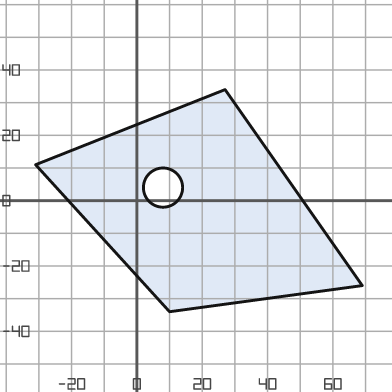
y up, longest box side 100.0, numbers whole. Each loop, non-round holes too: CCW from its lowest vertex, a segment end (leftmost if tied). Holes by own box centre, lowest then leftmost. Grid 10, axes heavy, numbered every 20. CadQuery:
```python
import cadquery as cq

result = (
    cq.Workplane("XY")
    .moveTo(10.0, -34.0)
    .lineTo(69.0, -26.0)
    .lineTo(27.0, 34.0)
    .lineTo(-31.0, 11.0)
    .close()
    .moveTo(8.0, 4.0)
    .circle(6.0)
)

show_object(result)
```